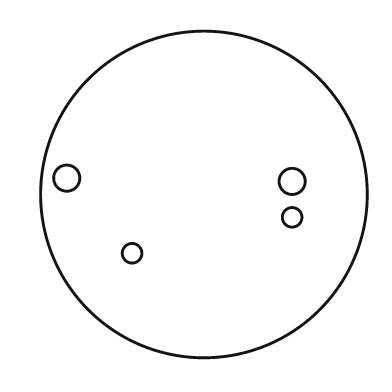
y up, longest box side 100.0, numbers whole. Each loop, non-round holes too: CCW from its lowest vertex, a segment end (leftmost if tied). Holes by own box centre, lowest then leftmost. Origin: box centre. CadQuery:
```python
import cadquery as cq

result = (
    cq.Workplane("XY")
    .moveTo(0.0, 0.0)
    .circle(50.0)
    .moveTo(-22.0, -18.0)
    .circle(3.0)
    .moveTo(27.0, -7.0)
    .circle(3.0)
    .moveTo(27.0, 4.0)
    .circle(4.0)
    .moveTo(-42.0, 5.0)
    .circle(4.0)
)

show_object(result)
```